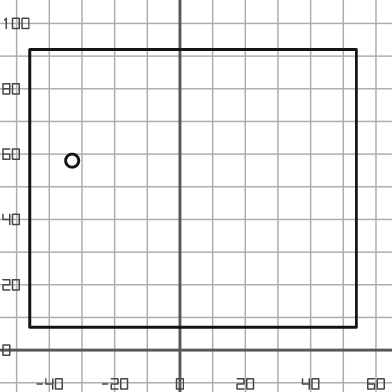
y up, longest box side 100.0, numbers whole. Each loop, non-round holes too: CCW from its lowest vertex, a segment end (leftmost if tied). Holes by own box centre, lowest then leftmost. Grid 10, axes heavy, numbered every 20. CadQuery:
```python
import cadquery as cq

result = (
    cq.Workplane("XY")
    .moveTo(-46.0, 7.0)
    .lineTo(54.0, 7.0)
    .lineTo(54.0, 92.0)
    .lineTo(-46.0, 92.0)
    .close()
    .moveTo(-33.0, 58.0)
    .circle(2.0)
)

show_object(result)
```